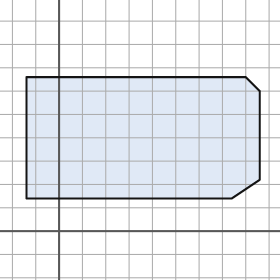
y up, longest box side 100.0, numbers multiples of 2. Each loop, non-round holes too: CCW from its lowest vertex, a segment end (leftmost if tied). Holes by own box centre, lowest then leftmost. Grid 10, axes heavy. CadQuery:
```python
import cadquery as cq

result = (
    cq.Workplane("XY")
    .moveTo(-14.0, 14.0)
    .lineTo(74.0, 14.0)
    .lineTo(86.0, 22.0)
    .lineTo(86.0, 60.0)
    .lineTo(80.0, 66.0)
    .lineTo(-14.0, 66.0)
    .close()
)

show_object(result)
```